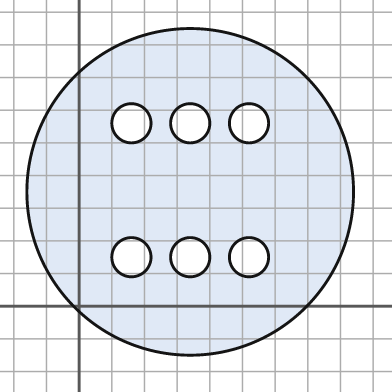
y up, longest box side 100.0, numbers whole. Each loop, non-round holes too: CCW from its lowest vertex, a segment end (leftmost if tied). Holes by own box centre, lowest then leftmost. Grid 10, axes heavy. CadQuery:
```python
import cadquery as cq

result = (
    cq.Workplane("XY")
    .moveTo(34.0, 35.0)
    .circle(50.0)
    .moveTo(16.0, 15.0)
    .circle(6.0)
    .moveTo(34.0, 15.0)
    .circle(6.0)
    .moveTo(52.0, 15.0)
    .circle(6.0)
    .moveTo(16.0, 56.0)
    .circle(6.0)
    .moveTo(34.0, 56.0)
    .circle(6.0)
    .moveTo(52.0, 56.0)
    .circle(6.0)
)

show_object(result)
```